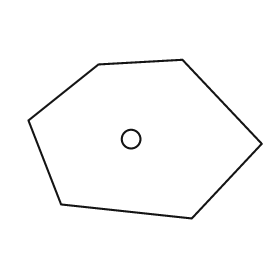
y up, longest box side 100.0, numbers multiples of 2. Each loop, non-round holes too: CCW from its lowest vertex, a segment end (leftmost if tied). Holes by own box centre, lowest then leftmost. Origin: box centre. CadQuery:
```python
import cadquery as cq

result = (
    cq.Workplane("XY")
    .moveTo(20.0, -34.0)
    .lineTo(50.0, -2.0)
    .lineTo(16.0, 34.0)
    .lineTo(-20.0, 32.0)
    .lineTo(-50.0, 8.0)
    .lineTo(-36.0, -28.0)
    .close()
    .moveTo(-6.0, 0.0)
    .circle(4.0)
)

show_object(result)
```